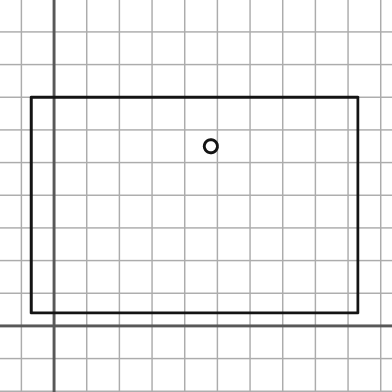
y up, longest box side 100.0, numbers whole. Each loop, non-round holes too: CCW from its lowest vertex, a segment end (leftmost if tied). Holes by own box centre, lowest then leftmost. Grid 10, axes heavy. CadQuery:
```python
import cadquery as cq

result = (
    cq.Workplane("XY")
    .moveTo(-7.0, 4.0)
    .lineTo(93.0, 4.0)
    .lineTo(93.0, 70.0)
    .lineTo(-7.0, 70.0)
    .close()
    .moveTo(48.0, 55.0)
    .circle(2.0)
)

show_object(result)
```